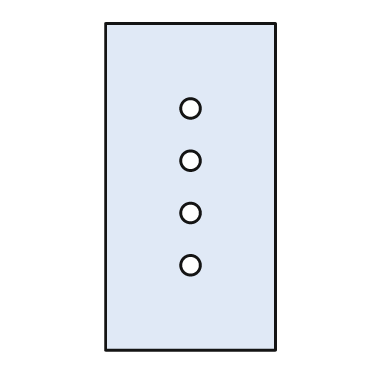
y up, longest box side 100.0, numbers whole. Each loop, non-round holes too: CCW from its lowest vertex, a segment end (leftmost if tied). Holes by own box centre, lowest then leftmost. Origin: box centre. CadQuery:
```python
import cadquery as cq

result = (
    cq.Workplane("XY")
    .moveTo(-26.0, -50.0)
    .lineTo(26.0, -50.0)
    .lineTo(26.0, 50.0)
    .lineTo(-26.0, 50.0)
    .close()
    .moveTo(0.0, -24.0)
    .circle(3.0)
    .moveTo(0.0, -8.0)
    .circle(3.0)
    .moveTo(0.0, 8.0)
    .circle(3.0)
    .moveTo(0.0, 24.0)
    .circle(3.0)
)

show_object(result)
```